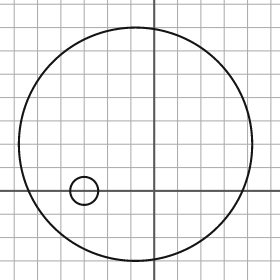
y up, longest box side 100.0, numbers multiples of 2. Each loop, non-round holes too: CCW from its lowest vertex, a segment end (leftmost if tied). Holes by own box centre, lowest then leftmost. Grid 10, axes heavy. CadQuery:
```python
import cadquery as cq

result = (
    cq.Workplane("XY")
    .moveTo(-8.0, 20.0)
    .circle(50.0)
    .moveTo(-30.0, 0.0)
    .circle(6.0)
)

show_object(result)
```